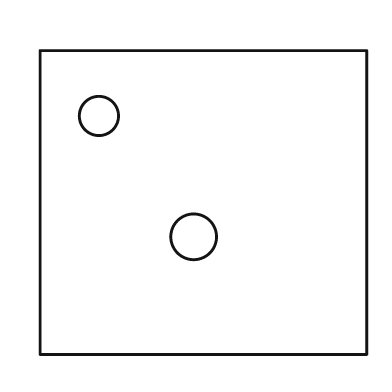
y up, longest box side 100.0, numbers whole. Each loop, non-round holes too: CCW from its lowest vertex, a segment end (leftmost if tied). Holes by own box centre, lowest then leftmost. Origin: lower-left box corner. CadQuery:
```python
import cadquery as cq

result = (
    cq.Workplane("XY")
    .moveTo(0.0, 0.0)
    .lineTo(100.0, 0.0)
    .lineTo(100.0, 93.0)
    .lineTo(0.0, 93.0)
    .close()
    .moveTo(47.0, 36.0)
    .circle(7.0)
    .moveTo(18.0, 73.0)
    .circle(6.0)
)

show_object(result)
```